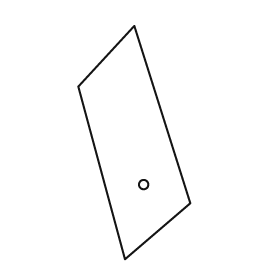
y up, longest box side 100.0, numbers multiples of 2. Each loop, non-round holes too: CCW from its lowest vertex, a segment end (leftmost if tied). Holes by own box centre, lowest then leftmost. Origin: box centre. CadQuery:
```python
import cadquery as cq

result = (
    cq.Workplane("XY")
    .moveTo(-4.0, -50.0)
    .lineTo(24.0, -26.0)
    .lineTo(0.0, 50.0)
    .lineTo(-24.0, 24.0)
    .close()
    .moveTo(4.0, -18.0)
    .circle(2.0)
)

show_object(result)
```